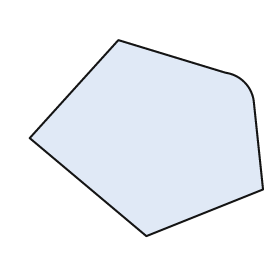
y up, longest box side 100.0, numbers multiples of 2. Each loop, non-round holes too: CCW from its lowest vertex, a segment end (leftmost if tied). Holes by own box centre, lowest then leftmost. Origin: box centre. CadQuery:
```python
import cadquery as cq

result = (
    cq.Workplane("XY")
    .moveTo(0.0, -42.0)
    .lineTo(50.0, -22.0)
    .lineTo(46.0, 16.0)
    .threePointArc((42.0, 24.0), (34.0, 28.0))
    .lineTo(-12.0, 42.0)
    .lineTo(-50.0, 0.0)
    .close()
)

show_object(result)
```